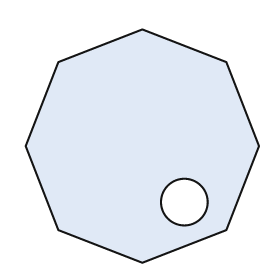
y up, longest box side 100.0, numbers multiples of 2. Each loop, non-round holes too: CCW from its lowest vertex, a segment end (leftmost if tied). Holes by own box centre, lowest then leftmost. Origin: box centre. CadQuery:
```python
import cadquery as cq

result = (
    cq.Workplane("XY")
    .moveTo(0.0, -50.0)
    .lineTo(36.0, -36.0)
    .lineTo(50.0, 0.0)
    .lineTo(36.0, 36.0)
    .lineTo(0.0, 50.0)
    .lineTo(-36.0, 36.0)
    .lineTo(-50.0, 0.0)
    .lineTo(-36.0, -36.0)
    .close()
    .moveTo(18.0, -24.0)
    .circle(10.0)
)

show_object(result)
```